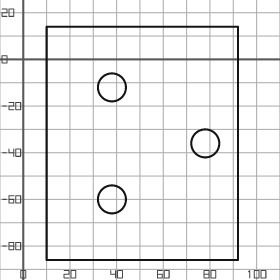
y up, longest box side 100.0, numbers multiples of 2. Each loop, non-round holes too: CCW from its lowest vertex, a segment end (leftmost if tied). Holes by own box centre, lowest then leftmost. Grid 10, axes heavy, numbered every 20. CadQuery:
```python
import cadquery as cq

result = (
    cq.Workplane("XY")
    .moveTo(10.0, -86.0)
    .lineTo(92.0, -86.0)
    .lineTo(92.0, 14.0)
    .lineTo(10.0, 14.0)
    .close()
    .moveTo(38.0, -60.0)
    .circle(6.0)
    .moveTo(78.0, -36.0)
    .circle(6.0)
    .moveTo(38.0, -12.0)
    .circle(6.0)
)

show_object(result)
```